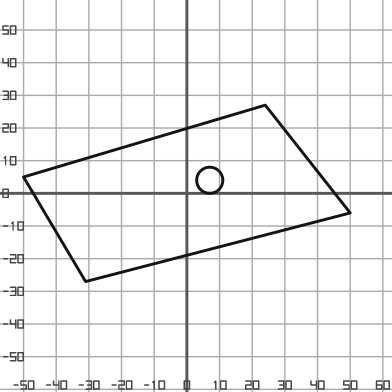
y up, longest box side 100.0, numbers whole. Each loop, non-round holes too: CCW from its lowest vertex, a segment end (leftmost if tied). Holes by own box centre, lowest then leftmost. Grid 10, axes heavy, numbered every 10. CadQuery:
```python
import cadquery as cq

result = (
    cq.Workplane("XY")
    .moveTo(-31.0, -27.0)
    .lineTo(50.0, -6.0)
    .lineTo(24.0, 27.0)
    .lineTo(-50.0, 5.0)
    .close()
    .moveTo(7.0, 4.0)
    .circle(4.0)
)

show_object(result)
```